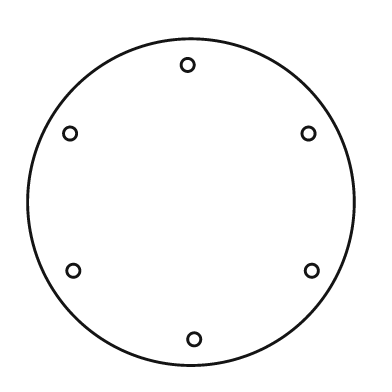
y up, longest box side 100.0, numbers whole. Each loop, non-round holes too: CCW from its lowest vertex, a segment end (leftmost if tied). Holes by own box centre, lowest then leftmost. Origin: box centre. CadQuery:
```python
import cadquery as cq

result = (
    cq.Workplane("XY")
    .moveTo(0.0, 0.0)
    .circle(50.0)
    .moveTo(1.0, -42.0)
    .circle(2.0)
    .moveTo(-36.0, -21.0)
    .circle(2.0)
    .moveTo(37.0, -21.0)
    .circle(2.0)
    .moveTo(-37.0, 21.0)
    .circle(2.0)
    .moveTo(36.0, 21.0)
    .circle(2.0)
    .moveTo(-1.0, 42.0)
    .circle(2.0)
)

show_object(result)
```